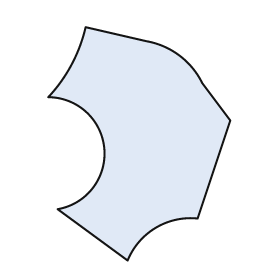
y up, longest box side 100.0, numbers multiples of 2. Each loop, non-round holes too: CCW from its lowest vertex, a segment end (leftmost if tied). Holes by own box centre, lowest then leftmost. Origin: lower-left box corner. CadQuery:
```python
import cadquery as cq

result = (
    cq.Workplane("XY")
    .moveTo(34.0, 0.0)
    .threePointArc((46.0, 14.0), (64.0, 18.0))
    .lineTo(78.0, 60.0)
    .lineTo(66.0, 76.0)
    .threePointArc((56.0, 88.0), (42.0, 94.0))
    .lineTo(16.0, 100.0)
    .threePointArc((10.0, 84.0), (0.0, 70.0))
    .threePointArc((24.0, 48.0), (4.0, 22.0))
    .close()
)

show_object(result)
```